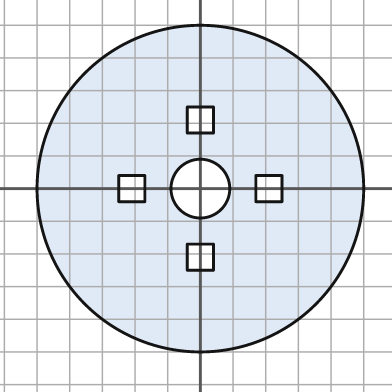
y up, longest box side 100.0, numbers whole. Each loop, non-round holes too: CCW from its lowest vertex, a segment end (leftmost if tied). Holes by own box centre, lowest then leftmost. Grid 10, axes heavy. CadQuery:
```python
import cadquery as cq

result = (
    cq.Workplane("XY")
    .moveTo(0.0, 0.0)
    .circle(50.0)
    .moveTo(-4.0, -25.0)
    .lineTo(4.0, -25.0)
    .lineTo(4.0, -17.0)
    .lineTo(-4.0, -17.0)
    .close()
    .moveTo(-25.0, -4.0)
    .lineTo(-17.0, -4.0)
    .lineTo(-17.0, 4.0)
    .lineTo(-25.0, 4.0)
    .close()
    .moveTo(0.0, 0.0)
    .circle(9.0)
    .moveTo(17.0, -4.0)
    .lineTo(25.0, -4.0)
    .lineTo(25.0, 4.0)
    .lineTo(17.0, 4.0)
    .close()
    .moveTo(-4.0, 17.0)
    .lineTo(4.0, 17.0)
    .lineTo(4.0, 25.0)
    .lineTo(-4.0, 25.0)
    .close()
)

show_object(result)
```